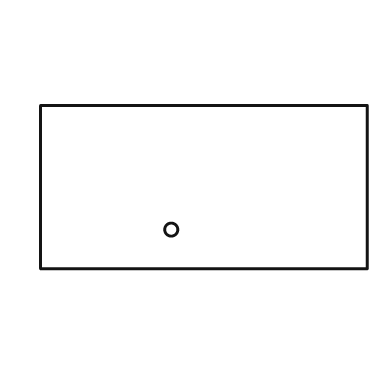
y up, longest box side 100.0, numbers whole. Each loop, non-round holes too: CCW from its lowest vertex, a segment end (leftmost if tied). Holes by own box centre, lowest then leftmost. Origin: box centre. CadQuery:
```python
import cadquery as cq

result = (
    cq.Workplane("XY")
    .moveTo(-50.0, -25.0)
    .lineTo(50.0, -25.0)
    .lineTo(50.0, 25.0)
    .lineTo(-50.0, 25.0)
    .close()
    .moveTo(-10.0, -13.0)
    .circle(2.0)
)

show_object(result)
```